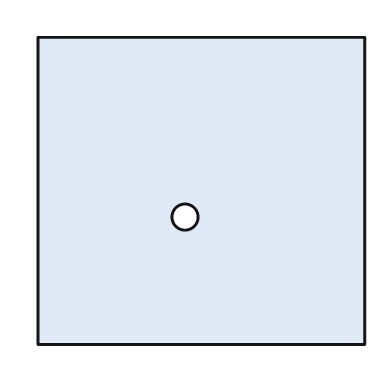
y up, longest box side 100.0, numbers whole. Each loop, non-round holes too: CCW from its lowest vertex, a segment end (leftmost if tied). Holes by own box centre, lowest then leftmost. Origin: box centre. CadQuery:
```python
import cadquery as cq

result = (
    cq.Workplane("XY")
    .moveTo(-50.0, -47.0)
    .lineTo(50.0, -47.0)
    .lineTo(50.0, 47.0)
    .lineTo(-50.0, 47.0)
    .close()
    .moveTo(-5.0, -8.0)
    .circle(4.0)
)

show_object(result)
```